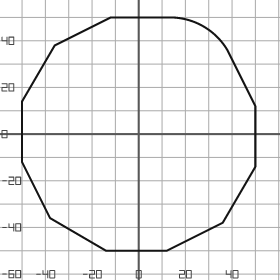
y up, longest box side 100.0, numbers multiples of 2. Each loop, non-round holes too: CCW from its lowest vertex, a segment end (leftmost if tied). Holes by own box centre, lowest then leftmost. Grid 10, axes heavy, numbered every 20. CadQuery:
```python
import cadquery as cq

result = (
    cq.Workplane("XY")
    .moveTo(-14.0, -50.0)
    .lineTo(12.0, -50.0)
    .lineTo(36.0, -38.0)
    .lineTo(50.0, -14.0)
    .lineTo(50.0, 12.0)
    .lineTo(38.0, 36.0)
    .threePointArc((28.0, 46.0), (14.0, 50.0))
    .lineTo(-12.0, 50.0)
    .lineTo(-36.0, 38.0)
    .lineTo(-50.0, 14.0)
    .lineTo(-50.0, -12.0)
    .lineTo(-38.0, -36.0)
    .close()
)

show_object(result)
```